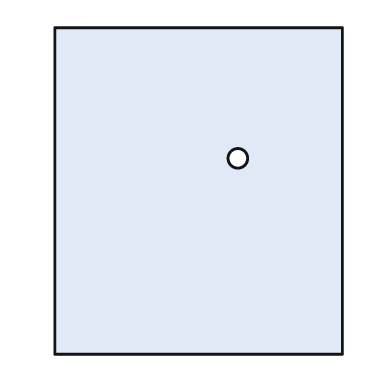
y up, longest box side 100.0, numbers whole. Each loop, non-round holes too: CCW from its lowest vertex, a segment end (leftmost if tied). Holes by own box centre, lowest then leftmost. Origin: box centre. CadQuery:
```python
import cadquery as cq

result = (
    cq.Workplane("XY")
    .moveTo(-44.0, -50.0)
    .lineTo(44.0, -50.0)
    .lineTo(44.0, 50.0)
    .lineTo(-44.0, 50.0)
    .close()
    .moveTo(12.0, 10.0)
    .circle(3.0)
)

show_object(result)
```